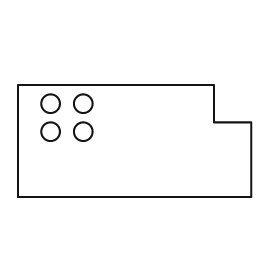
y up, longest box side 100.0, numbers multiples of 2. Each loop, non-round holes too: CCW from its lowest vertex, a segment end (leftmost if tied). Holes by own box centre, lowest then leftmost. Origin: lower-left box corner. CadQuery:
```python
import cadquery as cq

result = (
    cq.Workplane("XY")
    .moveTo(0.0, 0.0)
    .lineTo(100.0, 0.0)
    .lineTo(100.0, 32.0)
    .lineTo(84.0, 32.0)
    .lineTo(84.0, 48.0)
    .lineTo(0.0, 48.0)
    .close()
    .moveTo(14.0, 28.0)
    .circle(4.0)
    .moveTo(28.0, 28.0)
    .circle(4.0)
    .moveTo(14.0, 40.0)
    .circle(4.0)
    .moveTo(28.0, 40.0)
    .circle(4.0)
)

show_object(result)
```